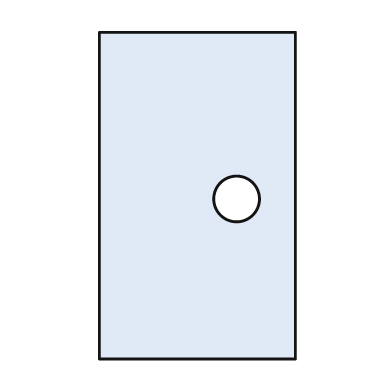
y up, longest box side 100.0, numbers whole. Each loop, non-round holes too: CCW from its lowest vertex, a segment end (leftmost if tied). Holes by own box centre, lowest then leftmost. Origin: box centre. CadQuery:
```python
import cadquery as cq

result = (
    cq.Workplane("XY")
    .moveTo(-30.0, -50.0)
    .lineTo(30.0, -50.0)
    .lineTo(30.0, 50.0)
    .lineTo(-30.0, 50.0)
    .close()
    .moveTo(12.0, -1.0)
    .circle(7.0)
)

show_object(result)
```